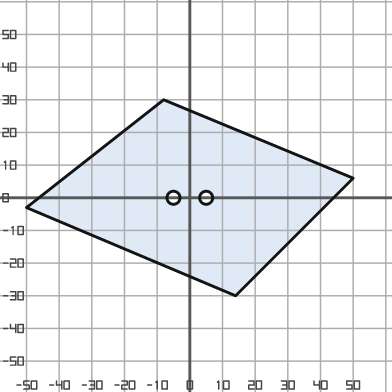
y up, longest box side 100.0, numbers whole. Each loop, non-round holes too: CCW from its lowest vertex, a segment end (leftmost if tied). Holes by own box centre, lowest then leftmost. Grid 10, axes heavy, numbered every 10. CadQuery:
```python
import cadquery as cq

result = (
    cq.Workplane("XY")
    .moveTo(14.0, -30.0)
    .lineTo(50.0, 6.0)
    .lineTo(-8.0, 30.0)
    .lineTo(-50.0, -3.0)
    .close()
    .moveTo(-5.0, 0.0)
    .circle(2.0)
    .moveTo(5.0, 0.0)
    .circle(2.0)
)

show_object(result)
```